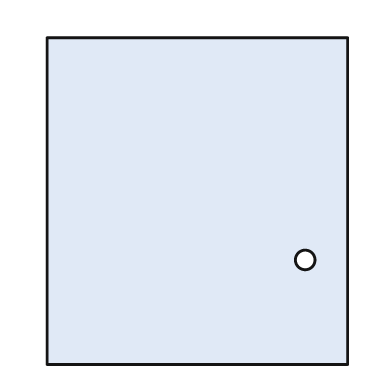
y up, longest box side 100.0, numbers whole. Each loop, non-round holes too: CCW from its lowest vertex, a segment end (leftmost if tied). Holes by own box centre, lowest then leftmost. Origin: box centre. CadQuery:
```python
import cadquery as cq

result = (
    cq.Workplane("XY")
    .moveTo(-46.0, -50.0)
    .lineTo(46.0, -50.0)
    .lineTo(46.0, 50.0)
    .lineTo(-46.0, 50.0)
    .close()
    .moveTo(33.0, -18.0)
    .circle(3.0)
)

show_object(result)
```